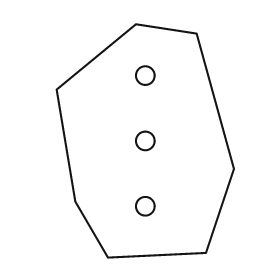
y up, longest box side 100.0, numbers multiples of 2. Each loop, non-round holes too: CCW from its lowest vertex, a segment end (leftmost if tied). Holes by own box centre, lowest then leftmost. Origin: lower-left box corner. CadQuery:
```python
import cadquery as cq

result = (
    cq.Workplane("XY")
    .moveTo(22.0, 0.0)
    .lineTo(64.0, 2.0)
    .lineTo(76.0, 38.0)
    .lineTo(60.0, 96.0)
    .lineTo(34.0, 100.0)
    .lineTo(0.0, 72.0)
    .lineTo(8.0, 24.0)
    .close()
    .moveTo(38.0, 22.0)
    .circle(4.0)
    .moveTo(38.0, 50.0)
    .circle(4.0)
    .moveTo(38.0, 78.0)
    .circle(4.0)
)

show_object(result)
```